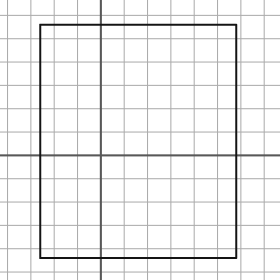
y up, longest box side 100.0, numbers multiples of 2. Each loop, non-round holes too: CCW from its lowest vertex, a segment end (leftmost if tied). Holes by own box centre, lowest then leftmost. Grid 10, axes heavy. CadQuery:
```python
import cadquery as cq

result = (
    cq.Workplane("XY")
    .moveTo(-26.0, -44.0)
    .lineTo(58.0, -44.0)
    .lineTo(58.0, 56.0)
    .lineTo(-26.0, 56.0)
    .close()
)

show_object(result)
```